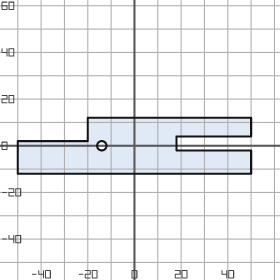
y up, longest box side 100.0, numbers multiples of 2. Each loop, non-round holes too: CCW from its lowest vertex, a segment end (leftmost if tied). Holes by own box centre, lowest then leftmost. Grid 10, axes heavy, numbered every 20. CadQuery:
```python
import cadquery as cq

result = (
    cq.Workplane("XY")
    .moveTo(-50.0, -12.0)
    .lineTo(50.0, -12.0)
    .lineTo(50.0, -2.0)
    .lineTo(18.0, -2.0)
    .lineTo(18.0, 4.0)
    .lineTo(50.0, 4.0)
    .lineTo(50.0, 12.0)
    .lineTo(-20.0, 12.0)
    .lineTo(-20.0, 2.0)
    .lineTo(-50.0, 2.0)
    .close()
    .moveTo(-14.0, 0.0)
    .circle(2.0)
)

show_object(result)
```